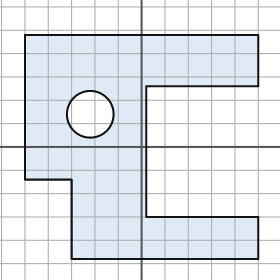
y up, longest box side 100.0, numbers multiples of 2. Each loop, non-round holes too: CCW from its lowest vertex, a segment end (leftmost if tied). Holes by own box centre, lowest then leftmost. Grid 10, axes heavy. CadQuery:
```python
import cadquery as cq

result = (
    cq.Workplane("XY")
    .moveTo(-30.0, -48.0)
    .lineTo(50.0, -48.0)
    .lineTo(50.0, -30.0)
    .lineTo(2.0, -30.0)
    .lineTo(2.0, 26.0)
    .lineTo(50.0, 26.0)
    .lineTo(50.0, 48.0)
    .lineTo(-50.0, 48.0)
    .lineTo(-50.0, -14.0)
    .lineTo(-30.0, -14.0)
    .close()
    .moveTo(-22.0, 14.0)
    .circle(10.0)
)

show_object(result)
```